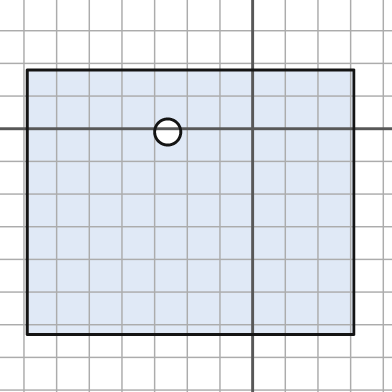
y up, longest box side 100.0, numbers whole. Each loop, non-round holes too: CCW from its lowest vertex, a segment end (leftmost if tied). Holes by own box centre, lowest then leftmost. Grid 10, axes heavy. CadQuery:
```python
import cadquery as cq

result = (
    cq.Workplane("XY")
    .moveTo(-69.0, -63.0)
    .lineTo(31.0, -63.0)
    .lineTo(31.0, 18.0)
    .lineTo(-69.0, 18.0)
    .close()
    .moveTo(-26.0, -1.0)
    .circle(4.0)
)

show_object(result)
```